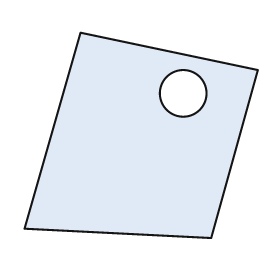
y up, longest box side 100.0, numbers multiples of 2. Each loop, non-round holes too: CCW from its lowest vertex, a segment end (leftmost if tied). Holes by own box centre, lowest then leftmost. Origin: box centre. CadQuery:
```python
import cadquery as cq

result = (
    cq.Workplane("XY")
    .moveTo(30.0, -44.0)
    .lineTo(50.0, 28.0)
    .lineTo(-26.0, 44.0)
    .lineTo(-50.0, -40.0)
    .close()
    .moveTo(18.0, 18.0)
    .circle(10.0)
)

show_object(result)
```